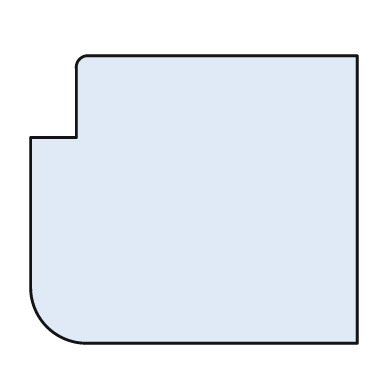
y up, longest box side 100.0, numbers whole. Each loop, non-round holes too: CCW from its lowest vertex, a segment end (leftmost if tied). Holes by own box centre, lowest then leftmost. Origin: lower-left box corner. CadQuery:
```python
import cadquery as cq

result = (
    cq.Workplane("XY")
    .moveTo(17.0, 0.0)
    .lineTo(100.0, 0.0)
    .lineTo(100.0, 88.0)
    .lineTo(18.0, 88.0)
    .threePointArc((15.0, 87.0), (14.0, 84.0))
    .lineTo(14.0, 63.0)
    .lineTo(0.0, 63.0)
    .lineTo(0.0, 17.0)
    .threePointArc((5.0, 5.0), (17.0, 0.0))
    .close()
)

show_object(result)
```